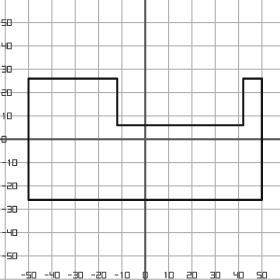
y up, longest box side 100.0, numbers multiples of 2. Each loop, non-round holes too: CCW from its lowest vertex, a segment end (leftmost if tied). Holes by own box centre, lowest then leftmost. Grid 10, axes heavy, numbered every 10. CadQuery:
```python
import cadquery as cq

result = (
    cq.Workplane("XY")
    .moveTo(-50.0, -26.0)
    .lineTo(50.0, -26.0)
    .lineTo(50.0, 26.0)
    .lineTo(42.0, 26.0)
    .lineTo(42.0, 6.0)
    .lineTo(-12.0, 6.0)
    .lineTo(-12.0, 26.0)
    .lineTo(-50.0, 26.0)
    .close()
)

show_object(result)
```